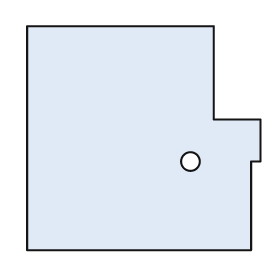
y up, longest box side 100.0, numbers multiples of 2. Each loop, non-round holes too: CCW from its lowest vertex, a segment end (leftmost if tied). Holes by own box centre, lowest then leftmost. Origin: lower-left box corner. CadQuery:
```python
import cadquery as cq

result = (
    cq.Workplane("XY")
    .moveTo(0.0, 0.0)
    .lineTo(96.0, 0.0)
    .lineTo(96.0, 38.0)
    .lineTo(100.0, 38.0)
    .lineTo(100.0, 56.0)
    .lineTo(80.0, 56.0)
    .lineTo(80.0, 96.0)
    .lineTo(0.0, 96.0)
    .close()
    .moveTo(70.0, 38.0)
    .circle(4.0)
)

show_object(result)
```